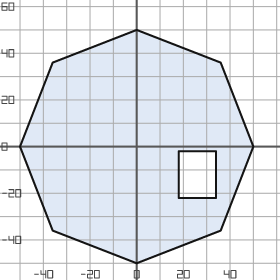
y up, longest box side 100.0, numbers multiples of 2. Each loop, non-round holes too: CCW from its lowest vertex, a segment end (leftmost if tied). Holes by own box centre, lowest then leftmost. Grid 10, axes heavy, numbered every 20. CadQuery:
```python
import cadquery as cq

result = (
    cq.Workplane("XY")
    .moveTo(0.0, -50.0)
    .lineTo(36.0, -36.0)
    .lineTo(50.0, 0.0)
    .lineTo(36.0, 36.0)
    .lineTo(0.0, 50.0)
    .lineTo(-36.0, 36.0)
    .lineTo(-50.0, 0.0)
    .lineTo(-36.0, -36.0)
    .close()
    .moveTo(18.0, -22.0)
    .lineTo(34.0, -22.0)
    .lineTo(34.0, -2.0)
    .lineTo(18.0, -2.0)
    .close()
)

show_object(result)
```